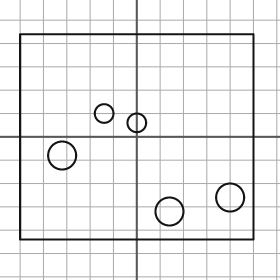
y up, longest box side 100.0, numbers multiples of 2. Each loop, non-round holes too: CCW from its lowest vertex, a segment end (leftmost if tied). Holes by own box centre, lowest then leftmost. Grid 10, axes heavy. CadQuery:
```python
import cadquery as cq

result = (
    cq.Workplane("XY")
    .moveTo(-50.0, -44.0)
    .lineTo(50.0, -44.0)
    .lineTo(50.0, 44.0)
    .lineTo(-50.0, 44.0)
    .close()
    .moveTo(14.0, -32.0)
    .circle(6.0)
    .moveTo(40.0, -26.0)
    .circle(6.0)
    .moveTo(-32.0, -8.0)
    .circle(6.0)
    .moveTo(0.0, 6.0)
    .circle(4.0)
    .moveTo(-14.0, 10.0)
    .circle(4.0)
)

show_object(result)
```